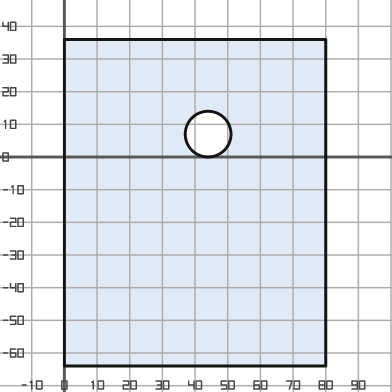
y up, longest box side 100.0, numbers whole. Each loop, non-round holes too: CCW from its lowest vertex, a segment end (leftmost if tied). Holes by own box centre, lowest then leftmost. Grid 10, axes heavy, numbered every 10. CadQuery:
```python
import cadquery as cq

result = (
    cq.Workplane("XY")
    .moveTo(0.0, -64.0)
    .lineTo(80.0, -64.0)
    .lineTo(80.0, 36.0)
    .lineTo(0.0, 36.0)
    .close()
    .moveTo(44.0, 7.0)
    .circle(7.0)
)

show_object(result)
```